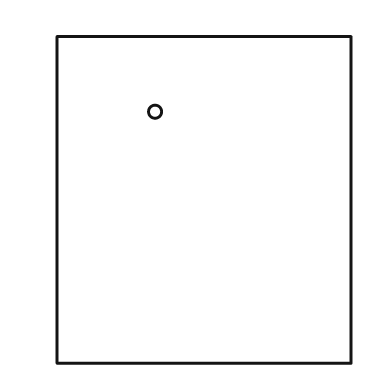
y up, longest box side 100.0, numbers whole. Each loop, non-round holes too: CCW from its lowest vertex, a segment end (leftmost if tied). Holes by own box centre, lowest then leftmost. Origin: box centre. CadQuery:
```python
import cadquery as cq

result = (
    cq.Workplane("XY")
    .moveTo(-45.0, -50.0)
    .lineTo(45.0, -50.0)
    .lineTo(45.0, 50.0)
    .lineTo(-45.0, 50.0)
    .close()
    .moveTo(-15.0, 27.0)
    .circle(2.0)
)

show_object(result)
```